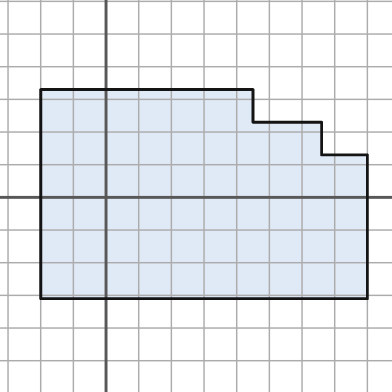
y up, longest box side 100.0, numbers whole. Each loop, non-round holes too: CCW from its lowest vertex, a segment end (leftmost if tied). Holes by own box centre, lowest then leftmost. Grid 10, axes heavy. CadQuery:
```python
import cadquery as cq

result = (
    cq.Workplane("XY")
    .moveTo(-20.0, -31.0)
    .lineTo(80.0, -31.0)
    .lineTo(80.0, 13.0)
    .lineTo(66.0, 13.0)
    .lineTo(66.0, 23.0)
    .lineTo(45.0, 23.0)
    .lineTo(45.0, 33.0)
    .lineTo(-20.0, 33.0)
    .close()
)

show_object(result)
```